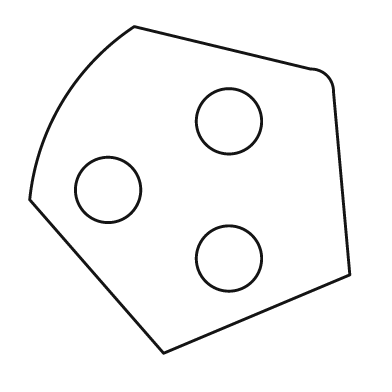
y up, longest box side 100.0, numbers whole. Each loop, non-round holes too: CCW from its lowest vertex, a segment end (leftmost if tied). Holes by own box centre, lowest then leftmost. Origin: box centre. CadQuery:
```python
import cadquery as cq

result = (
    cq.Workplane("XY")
    .moveTo(-8.0, -50.0)
    .lineTo(49.0, -26.0)
    .lineTo(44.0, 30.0)
    .threePointArc((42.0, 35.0), (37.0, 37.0))
    .lineTo(-17.0, 50.0)
    .threePointArc((-39.0, 27.0), (-49.0, -3.0))
    .close()
    .moveTo(12.0, -21.0)
    .circle(10.0)
    .moveTo(-25.0, 0.0)
    .circle(10.0)
    .moveTo(12.0, 21.0)
    .circle(10.0)
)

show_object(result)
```